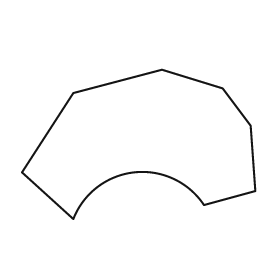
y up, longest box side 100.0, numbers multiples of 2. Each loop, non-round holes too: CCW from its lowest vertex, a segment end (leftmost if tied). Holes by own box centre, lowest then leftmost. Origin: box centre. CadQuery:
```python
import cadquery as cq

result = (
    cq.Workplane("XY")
    .moveTo(-28.0, -32.0)
    .threePointArc((-2.0, -12.0), (28.0, -26.0))
    .lineTo(50.0, -20.0)
    .lineTo(48.0, 8.0)
    .lineTo(36.0, 24.0)
    .lineTo(10.0, 32.0)
    .lineTo(-28.0, 22.0)
    .lineTo(-50.0, -12.0)
    .close()
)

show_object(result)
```